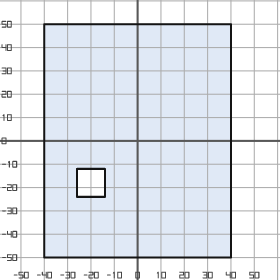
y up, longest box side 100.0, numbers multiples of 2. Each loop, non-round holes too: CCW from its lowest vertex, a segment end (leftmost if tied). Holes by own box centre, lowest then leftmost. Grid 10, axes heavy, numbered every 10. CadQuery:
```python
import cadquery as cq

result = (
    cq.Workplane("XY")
    .moveTo(-40.0, -50.0)
    .lineTo(40.0, -50.0)
    .lineTo(40.0, 50.0)
    .lineTo(-40.0, 50.0)
    .close()
    .moveTo(-26.0, -24.0)
    .lineTo(-14.0, -24.0)
    .lineTo(-14.0, -12.0)
    .lineTo(-26.0, -12.0)
    .close()
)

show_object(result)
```